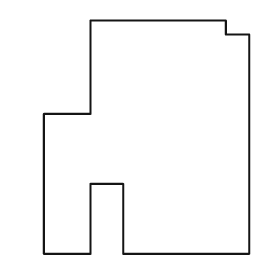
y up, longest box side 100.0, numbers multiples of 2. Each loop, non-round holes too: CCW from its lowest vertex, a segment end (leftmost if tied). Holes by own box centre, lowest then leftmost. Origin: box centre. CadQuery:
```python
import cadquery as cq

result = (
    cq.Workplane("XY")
    .moveTo(-44.0, -50.0)
    .lineTo(-24.0, -50.0)
    .lineTo(-24.0, -20.0)
    .lineTo(-10.0, -20.0)
    .lineTo(-10.0, -50.0)
    .lineTo(44.0, -50.0)
    .lineTo(44.0, 44.0)
    .lineTo(34.0, 44.0)
    .lineTo(34.0, 50.0)
    .lineTo(-24.0, 50.0)
    .lineTo(-24.0, 10.0)
    .lineTo(-44.0, 10.0)
    .close()
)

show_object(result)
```